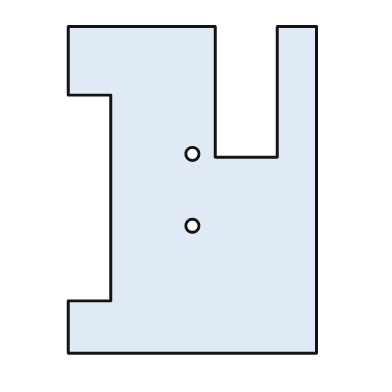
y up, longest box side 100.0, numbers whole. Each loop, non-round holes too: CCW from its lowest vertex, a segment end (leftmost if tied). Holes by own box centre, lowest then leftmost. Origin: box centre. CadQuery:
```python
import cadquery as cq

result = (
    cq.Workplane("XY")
    .moveTo(-38.0, -50.0)
    .lineTo(38.0, -50.0)
    .lineTo(38.0, 50.0)
    .lineTo(26.0, 50.0)
    .lineTo(26.0, 10.0)
    .lineTo(7.0, 10.0)
    .lineTo(7.0, 50.0)
    .lineTo(-38.0, 50.0)
    .lineTo(-38.0, 29.0)
    .lineTo(-25.0, 29.0)
    .lineTo(-25.0, -34.0)
    .lineTo(-38.0, -34.0)
    .close()
    .moveTo(0.0, -11.0)
    .circle(2.0)
    .moveTo(0.0, 11.0)
    .circle(2.0)
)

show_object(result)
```